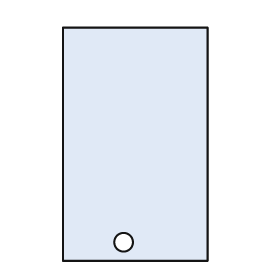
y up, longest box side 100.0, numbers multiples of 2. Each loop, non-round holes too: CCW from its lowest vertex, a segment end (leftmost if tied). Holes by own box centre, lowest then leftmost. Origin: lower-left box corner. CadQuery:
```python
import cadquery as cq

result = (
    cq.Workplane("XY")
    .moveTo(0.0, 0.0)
    .lineTo(62.0, 0.0)
    .lineTo(62.0, 100.0)
    .lineTo(0.0, 100.0)
    .close()
    .moveTo(26.0, 8.0)
    .circle(4.0)
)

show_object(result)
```